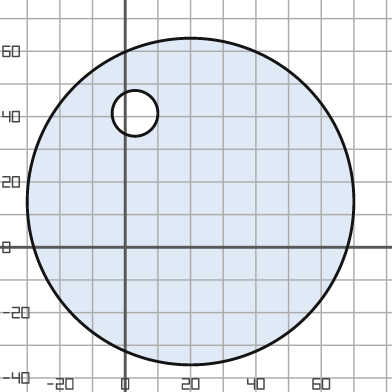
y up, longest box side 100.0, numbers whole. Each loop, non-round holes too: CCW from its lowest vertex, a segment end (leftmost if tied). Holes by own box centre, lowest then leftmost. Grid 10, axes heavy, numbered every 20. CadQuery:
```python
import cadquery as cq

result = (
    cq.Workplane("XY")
    .moveTo(20.0, 14.0)
    .circle(50.0)
    .moveTo(3.0, 41.0)
    .circle(7.0)
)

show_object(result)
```